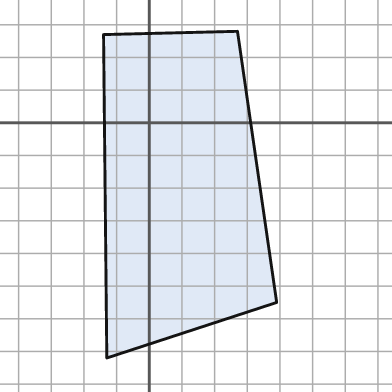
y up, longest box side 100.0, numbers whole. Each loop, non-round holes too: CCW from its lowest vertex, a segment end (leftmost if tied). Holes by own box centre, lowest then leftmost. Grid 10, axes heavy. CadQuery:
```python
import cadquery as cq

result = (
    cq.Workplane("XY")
    .moveTo(-13.0, -72.0)
    .lineTo(39.0, -55.0)
    .lineTo(27.0, 28.0)
    .lineTo(-14.0, 27.0)
    .close()
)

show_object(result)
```